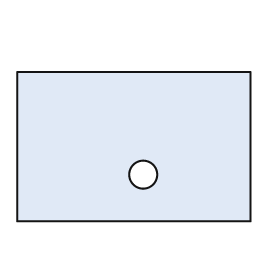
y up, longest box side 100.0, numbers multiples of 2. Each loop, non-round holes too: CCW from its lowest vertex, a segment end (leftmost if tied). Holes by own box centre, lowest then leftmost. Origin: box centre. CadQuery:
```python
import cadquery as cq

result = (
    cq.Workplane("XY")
    .moveTo(-50.0, -32.0)
    .lineTo(50.0, -32.0)
    .lineTo(50.0, 32.0)
    .lineTo(-50.0, 32.0)
    .close()
    .moveTo(4.0, -12.0)
    .circle(6.0)
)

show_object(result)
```